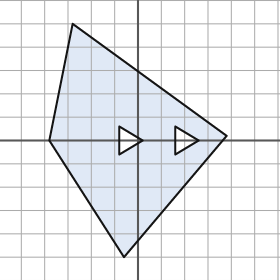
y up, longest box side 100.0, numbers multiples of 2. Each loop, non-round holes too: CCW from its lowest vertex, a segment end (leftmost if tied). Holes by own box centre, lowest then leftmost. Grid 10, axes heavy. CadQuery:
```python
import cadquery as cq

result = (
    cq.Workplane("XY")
    .moveTo(-6.0, -50.0)
    .lineTo(38.0, 2.0)
    .lineTo(-28.0, 50.0)
    .lineTo(-38.0, 0.0)
    .close()
    .moveTo(-8.0, -6.0)
    .lineTo(2.0, 0.0)
    .lineTo(-8.0, 6.0)
    .close()
    .moveTo(16.0, -6.0)
    .lineTo(26.0, 0.0)
    .lineTo(16.0, 6.0)
    .close()
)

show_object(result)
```